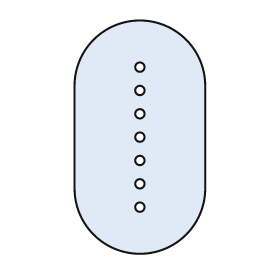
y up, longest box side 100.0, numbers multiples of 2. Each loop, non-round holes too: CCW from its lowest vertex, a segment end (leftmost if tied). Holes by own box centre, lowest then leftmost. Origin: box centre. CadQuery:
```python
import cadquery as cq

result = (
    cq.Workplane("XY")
    .moveTo(-28.0, -22.0)
    .threePointArc((0.0, -50.0), (28.0, -22.0))
    .lineTo(28.0, 22.0)
    .threePointArc((0.0, 50.0), (-28.0, 22.0))
    .close()
    .moveTo(0.0, -30.0)
    .circle(2.0)
    .moveTo(0.0, -20.0)
    .circle(2.0)
    .moveTo(0.0, -10.0)
    .circle(2.0)
    .moveTo(0.0, 0.0)
    .circle(2.0)
    .moveTo(0.0, 10.0)
    .circle(2.0)
    .moveTo(0.0, 20.0)
    .circle(2.0)
    .moveTo(0.0, 30.0)
    .circle(2.0)
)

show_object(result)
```